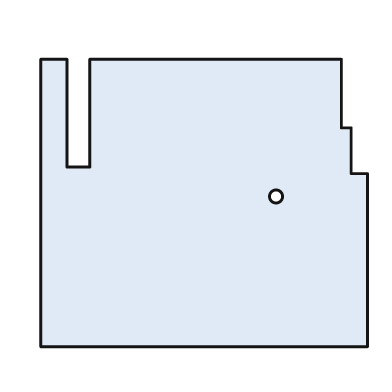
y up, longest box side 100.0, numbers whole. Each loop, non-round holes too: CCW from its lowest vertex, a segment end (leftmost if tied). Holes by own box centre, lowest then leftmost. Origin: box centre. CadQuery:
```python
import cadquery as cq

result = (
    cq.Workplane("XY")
    .moveTo(-50.0, -44.0)
    .lineTo(50.0, -44.0)
    .lineTo(50.0, 9.0)
    .lineTo(45.0, 9.0)
    .lineTo(45.0, 23.0)
    .lineTo(42.0, 23.0)
    .lineTo(42.0, 44.0)
    .lineTo(-35.0, 44.0)
    .lineTo(-35.0, 11.0)
    .lineTo(-42.0, 11.0)
    .lineTo(-42.0, 44.0)
    .lineTo(-50.0, 44.0)
    .close()
    .moveTo(22.0, 2.0)
    .circle(2.0)
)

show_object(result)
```